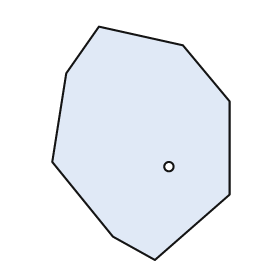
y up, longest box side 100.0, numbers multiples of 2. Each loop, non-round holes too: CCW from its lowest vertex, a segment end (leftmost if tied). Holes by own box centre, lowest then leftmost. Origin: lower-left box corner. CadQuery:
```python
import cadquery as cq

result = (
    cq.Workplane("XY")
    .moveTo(44.0, 0.0)
    .lineTo(76.0, 28.0)
    .lineTo(76.0, 68.0)
    .lineTo(56.0, 92.0)
    .lineTo(20.0, 100.0)
    .lineTo(6.0, 80.0)
    .lineTo(0.0, 42.0)
    .lineTo(26.0, 10.0)
    .close()
    .moveTo(50.0, 40.0)
    .circle(2.0)
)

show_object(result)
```